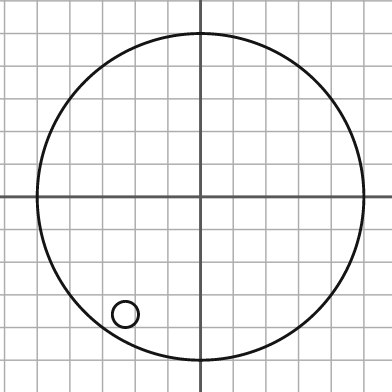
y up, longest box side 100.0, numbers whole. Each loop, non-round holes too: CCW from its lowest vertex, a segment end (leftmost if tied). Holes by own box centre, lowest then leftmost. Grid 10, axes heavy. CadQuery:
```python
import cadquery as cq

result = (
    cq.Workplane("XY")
    .moveTo(0.0, 0.0)
    .circle(50.0)
    .moveTo(-23.0, -36.0)
    .circle(4.0)
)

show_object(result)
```